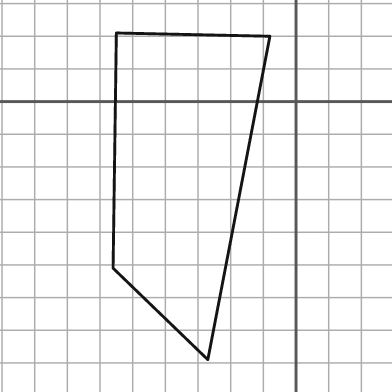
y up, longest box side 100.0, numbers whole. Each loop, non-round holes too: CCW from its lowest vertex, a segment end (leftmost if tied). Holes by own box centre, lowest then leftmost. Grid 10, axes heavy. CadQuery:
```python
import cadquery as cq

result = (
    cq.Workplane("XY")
    .moveTo(-27.0, -79.0)
    .lineTo(-8.0, 20.0)
    .lineTo(-55.0, 21.0)
    .lineTo(-56.0, -51.0)
    .close()
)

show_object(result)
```